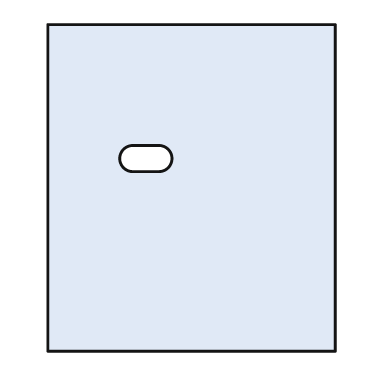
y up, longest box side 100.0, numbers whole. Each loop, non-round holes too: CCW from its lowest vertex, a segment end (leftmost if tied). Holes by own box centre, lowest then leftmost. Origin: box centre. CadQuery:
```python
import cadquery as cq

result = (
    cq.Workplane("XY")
    .moveTo(-44.0, -50.0)
    .lineTo(44.0, -50.0)
    .lineTo(44.0, 50.0)
    .lineTo(-44.0, 50.0)
    .close()
    .moveTo(-18.0, 5.0)
    .lineTo(-10.0, 5.0)
    .threePointArc((-6.0, 9.0), (-10.0, 13.0))
    .lineTo(-18.0, 13.0)
    .threePointArc((-22.0, 9.0), (-18.0, 5.0))
    .close()
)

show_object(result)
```